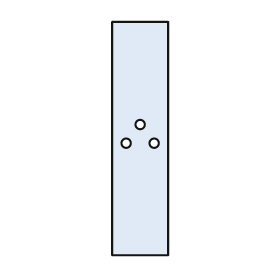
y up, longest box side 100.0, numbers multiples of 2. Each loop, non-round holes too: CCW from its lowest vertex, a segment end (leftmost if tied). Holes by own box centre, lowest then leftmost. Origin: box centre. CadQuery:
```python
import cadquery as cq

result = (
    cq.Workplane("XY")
    .moveTo(-12.0, -50.0)
    .lineTo(12.0, -50.0)
    .lineTo(12.0, 50.0)
    .lineTo(-12.0, 50.0)
    .close()
    .moveTo(-6.0, -2.0)
    .circle(2.0)
    .moveTo(6.0, -2.0)
    .circle(2.0)
    .moveTo(0.0, 6.0)
    .circle(2.0)
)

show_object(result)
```